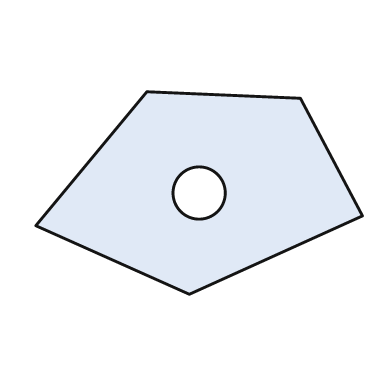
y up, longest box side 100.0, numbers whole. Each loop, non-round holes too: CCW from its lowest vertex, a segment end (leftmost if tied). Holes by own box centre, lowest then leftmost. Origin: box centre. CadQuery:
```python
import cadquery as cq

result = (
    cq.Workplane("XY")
    .moveTo(-3.0, -31.0)
    .lineTo(50.0, -7.0)
    .lineTo(31.0, 29.0)
    .lineTo(-16.0, 31.0)
    .lineTo(-50.0, -10.0)
    .close()
    .moveTo(0.0, 0.0)
    .circle(8.0)
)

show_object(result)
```